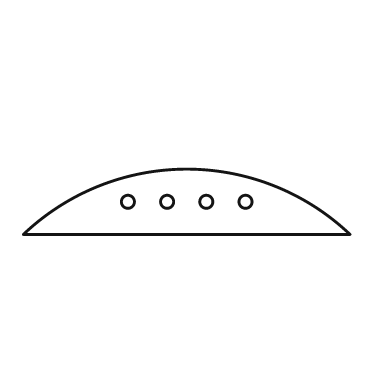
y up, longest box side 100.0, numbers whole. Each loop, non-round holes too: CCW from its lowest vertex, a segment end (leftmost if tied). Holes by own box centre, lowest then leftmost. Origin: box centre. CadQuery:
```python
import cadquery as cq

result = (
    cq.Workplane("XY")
    .moveTo(-50.0, -10.0)
    .lineTo(50.0, -10.0)
    .threePointArc((0.0, 10.0), (-50.0, -10.0))
    .close()
    .moveTo(-18.0, 0.0)
    .circle(2.0)
    .moveTo(-6.0, 0.0)
    .circle(2.0)
    .moveTo(6.0, 0.0)
    .circle(2.0)
    .moveTo(18.0, 0.0)
    .circle(2.0)
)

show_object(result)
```